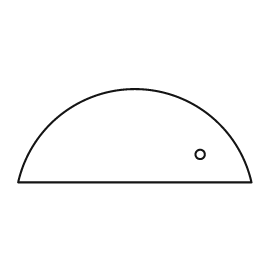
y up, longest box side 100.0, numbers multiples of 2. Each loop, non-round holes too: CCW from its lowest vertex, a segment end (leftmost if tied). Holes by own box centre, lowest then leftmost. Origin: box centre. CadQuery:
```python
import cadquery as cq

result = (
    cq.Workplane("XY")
    .moveTo(-50.0, -20.0)
    .lineTo(50.0, -20.0)
    .threePointArc((0.0, 20.0), (-50.0, -20.0))
    .close()
    .moveTo(28.0, -8.0)
    .circle(2.0)
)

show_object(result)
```